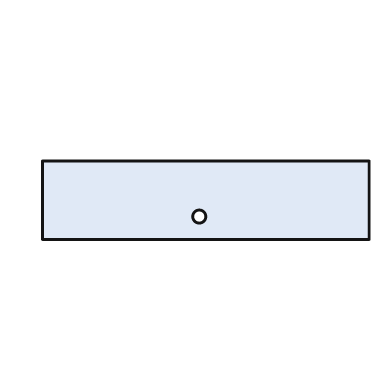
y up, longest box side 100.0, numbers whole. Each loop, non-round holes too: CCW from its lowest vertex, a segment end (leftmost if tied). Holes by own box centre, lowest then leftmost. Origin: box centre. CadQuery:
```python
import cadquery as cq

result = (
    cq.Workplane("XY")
    .moveTo(-50.0, -12.0)
    .lineTo(50.0, -12.0)
    .lineTo(50.0, 12.0)
    .lineTo(-50.0, 12.0)
    .close()
    .moveTo(-2.0, -5.0)
    .circle(2.0)
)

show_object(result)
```